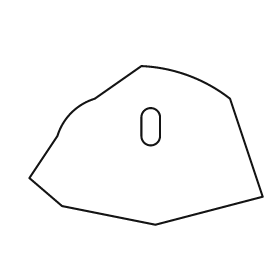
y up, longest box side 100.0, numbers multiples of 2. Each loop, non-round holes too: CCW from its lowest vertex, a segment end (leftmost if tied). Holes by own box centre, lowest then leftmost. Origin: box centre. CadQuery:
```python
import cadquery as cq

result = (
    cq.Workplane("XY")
    .moveTo(4.0, -34.0)
    .lineTo(50.0, -22.0)
    .lineTo(36.0, 20.0)
    .threePointArc((18.0, 30.0), (-2.0, 34.0))
    .lineTo(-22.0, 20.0)
    .threePointArc((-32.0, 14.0), (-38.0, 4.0))
    .lineTo(-50.0, -14.0)
    .lineTo(-36.0, -26.0)
    .close()
    .moveTo(-2.0, 4.0)
    .threePointArc((2.0, 0.0), (6.0, 4.0))
    .lineTo(6.0, 12.0)
    .threePointArc((2.0, 16.0), (-2.0, 12.0))
    .close()
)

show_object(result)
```